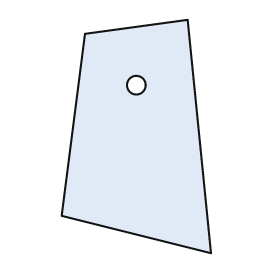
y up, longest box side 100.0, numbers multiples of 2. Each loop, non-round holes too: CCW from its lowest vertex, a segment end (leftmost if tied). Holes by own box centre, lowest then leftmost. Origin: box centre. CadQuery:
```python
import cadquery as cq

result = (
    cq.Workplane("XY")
    .moveTo(32.0, -50.0)
    .lineTo(22.0, 50.0)
    .lineTo(-22.0, 44.0)
    .lineTo(-32.0, -34.0)
    .close()
    .moveTo(0.0, 22.0)
    .circle(4.0)
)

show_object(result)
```